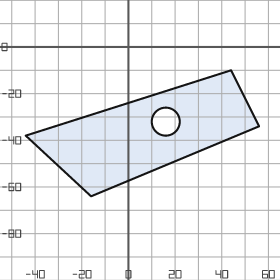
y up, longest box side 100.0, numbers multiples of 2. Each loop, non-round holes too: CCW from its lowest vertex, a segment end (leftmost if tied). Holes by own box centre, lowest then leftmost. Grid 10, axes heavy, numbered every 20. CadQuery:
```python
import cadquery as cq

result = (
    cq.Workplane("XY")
    .moveTo(-16.0, -64.0)
    .lineTo(56.0, -34.0)
    .lineTo(44.0, -10.0)
    .lineTo(-44.0, -38.0)
    .close()
    .moveTo(16.0, -32.0)
    .circle(6.0)
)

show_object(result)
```